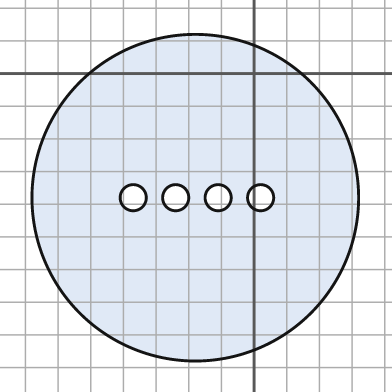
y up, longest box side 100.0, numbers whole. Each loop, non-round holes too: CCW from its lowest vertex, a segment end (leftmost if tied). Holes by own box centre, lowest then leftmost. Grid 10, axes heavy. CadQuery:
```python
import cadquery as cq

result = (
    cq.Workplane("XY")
    .moveTo(-18.0, -38.0)
    .circle(50.0)
    .moveTo(-37.0, -38.0)
    .circle(4.0)
    .moveTo(-24.0, -38.0)
    .circle(4.0)
    .moveTo(-11.0, -38.0)
    .circle(4.0)
    .moveTo(2.0, -38.0)
    .circle(4.0)
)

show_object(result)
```